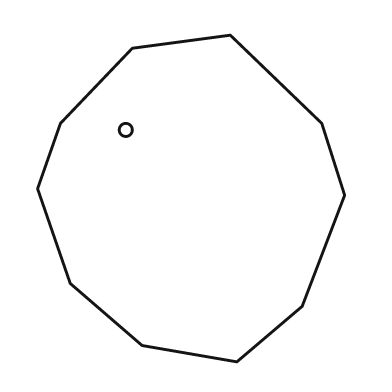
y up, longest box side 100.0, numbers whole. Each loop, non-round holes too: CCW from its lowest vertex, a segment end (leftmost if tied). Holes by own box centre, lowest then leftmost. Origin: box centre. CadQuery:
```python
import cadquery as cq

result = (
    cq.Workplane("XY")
    .moveTo(14.0, -50.0)
    .lineTo(34.0, -33.0)
    .lineTo(47.0, 1.0)
    .lineTo(40.0, 23.0)
    .lineTo(12.0, 50.0)
    .lineTo(-18.0, 46.0)
    .lineTo(-40.0, 23.0)
    .lineTo(-47.0, 3.0)
    .lineTo(-37.0, -26.0)
    .lineTo(-15.0, -45.0)
    .close()
    .moveTo(-20.0, 21.0)
    .circle(2.0)
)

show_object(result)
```